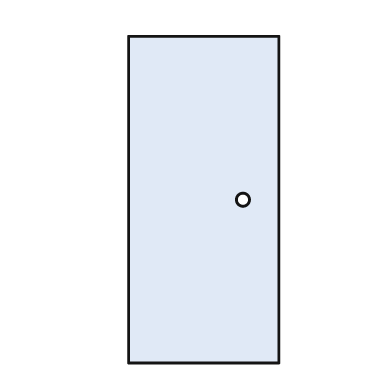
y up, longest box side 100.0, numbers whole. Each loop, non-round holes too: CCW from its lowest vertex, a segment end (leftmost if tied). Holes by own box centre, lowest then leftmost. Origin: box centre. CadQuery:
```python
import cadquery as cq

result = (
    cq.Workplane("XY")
    .moveTo(-23.0, -50.0)
    .lineTo(23.0, -50.0)
    .lineTo(23.0, 50.0)
    .lineTo(-23.0, 50.0)
    .close()
    .moveTo(12.0, 0.0)
    .circle(2.0)
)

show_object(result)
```